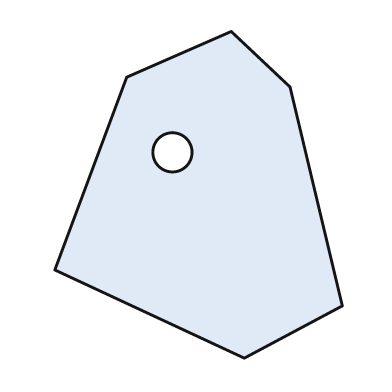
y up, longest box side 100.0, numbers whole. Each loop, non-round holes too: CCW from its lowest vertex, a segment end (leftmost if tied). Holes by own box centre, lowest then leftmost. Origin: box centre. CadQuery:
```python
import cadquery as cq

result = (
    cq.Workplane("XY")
    .moveTo(14.0, -50.0)
    .lineTo(44.0, -34.0)
    .lineTo(28.0, 33.0)
    .lineTo(10.0, 50.0)
    .lineTo(-22.0, 36.0)
    .lineTo(-44.0, -23.0)
    .close()
    .moveTo(-8.0, 13.0)
    .circle(6.0)
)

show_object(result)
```